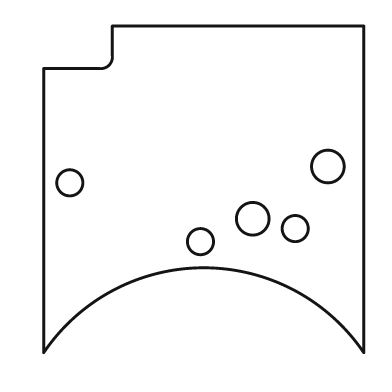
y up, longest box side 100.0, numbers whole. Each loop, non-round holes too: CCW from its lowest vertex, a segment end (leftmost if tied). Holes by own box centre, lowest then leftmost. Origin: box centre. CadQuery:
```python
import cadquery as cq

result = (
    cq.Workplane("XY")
    .moveTo(-49.0, -50.0)
    .threePointArc((0.0, -24.0), (49.0, -50.0))
    .lineTo(49.0, 50.0)
    .lineTo(-28.0, 50.0)
    .lineTo(-28.0, 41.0)
    .threePointArc((-29.0, 38.0), (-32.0, 37.0))
    .lineTo(-49.0, 37.0)
    .close()
    .moveTo(-1.0, -16.0)
    .circle(4.0)
    .moveTo(28.0, -12.0)
    .circle(4.0)
    .moveTo(15.0, -9.0)
    .circle(5.0)
    .moveTo(-41.0, 2.0)
    .circle(4.0)
    .moveTo(38.0, 7.0)
    .circle(5.0)
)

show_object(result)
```